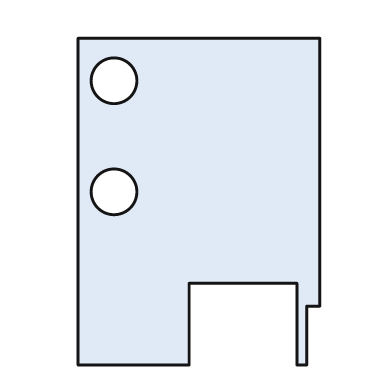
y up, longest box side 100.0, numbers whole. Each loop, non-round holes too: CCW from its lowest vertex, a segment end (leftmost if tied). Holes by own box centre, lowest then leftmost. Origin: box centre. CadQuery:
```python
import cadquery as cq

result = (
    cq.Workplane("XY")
    .moveTo(-37.0, -50.0)
    .lineTo(-3.0, -50.0)
    .lineTo(-3.0, -25.0)
    .lineTo(30.0, -25.0)
    .lineTo(30.0, -50.0)
    .lineTo(33.0, -50.0)
    .lineTo(33.0, -32.0)
    .lineTo(37.0, -32.0)
    .lineTo(37.0, 50.0)
    .lineTo(-37.0, 50.0)
    .close()
    .moveTo(-26.0, 3.0)
    .circle(7.0)
    .moveTo(-26.0, 37.0)
    .circle(7.0)
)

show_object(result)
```